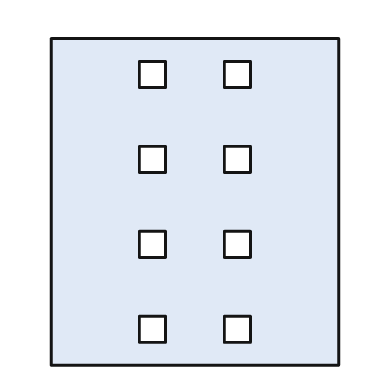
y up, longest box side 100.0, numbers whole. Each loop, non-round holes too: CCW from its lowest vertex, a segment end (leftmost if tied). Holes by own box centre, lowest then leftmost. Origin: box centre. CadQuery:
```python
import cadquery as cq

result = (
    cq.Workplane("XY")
    .moveTo(-44.0, -50.0)
    .lineTo(44.0, -50.0)
    .lineTo(44.0, 50.0)
    .lineTo(-44.0, 50.0)
    .close()
    .moveTo(-17.0, -43.0)
    .lineTo(-9.0, -43.0)
    .lineTo(-9.0, -35.0)
    .lineTo(-17.0, -35.0)
    .close()
    .moveTo(9.0, -43.0)
    .lineTo(17.0, -43.0)
    .lineTo(17.0, -35.0)
    .lineTo(9.0, -35.0)
    .close()
    .moveTo(-17.0, -17.0)
    .lineTo(-9.0, -17.0)
    .lineTo(-9.0, -9.0)
    .lineTo(-17.0, -9.0)
    .close()
    .moveTo(9.0, -17.0)
    .lineTo(17.0, -17.0)
    .lineTo(17.0, -9.0)
    .lineTo(9.0, -9.0)
    .close()
    .moveTo(-17.0, 9.0)
    .lineTo(-9.0, 9.0)
    .lineTo(-9.0, 17.0)
    .lineTo(-17.0, 17.0)
    .close()
    .moveTo(9.0, 9.0)
    .lineTo(17.0, 9.0)
    .lineTo(17.0, 17.0)
    .lineTo(9.0, 17.0)
    .close()
    .moveTo(-17.0, 35.0)
    .lineTo(-9.0, 35.0)
    .lineTo(-9.0, 43.0)
    .lineTo(-17.0, 43.0)
    .close()
    .moveTo(9.0, 35.0)
    .lineTo(17.0, 35.0)
    .lineTo(17.0, 43.0)
    .lineTo(9.0, 43.0)
    .close()
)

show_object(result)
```